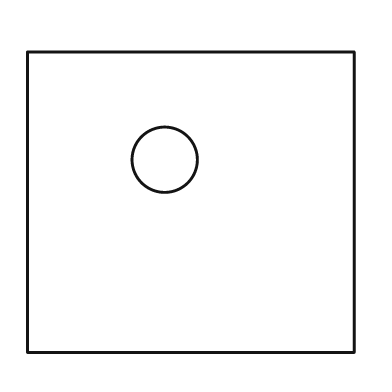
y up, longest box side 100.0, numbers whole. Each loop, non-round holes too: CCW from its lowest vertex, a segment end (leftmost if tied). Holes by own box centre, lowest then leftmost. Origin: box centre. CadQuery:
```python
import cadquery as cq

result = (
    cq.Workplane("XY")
    .moveTo(-50.0, -46.0)
    .lineTo(50.0, -46.0)
    .lineTo(50.0, 46.0)
    .lineTo(-50.0, 46.0)
    .close()
    .moveTo(-8.0, 13.0)
    .circle(10.0)
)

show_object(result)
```